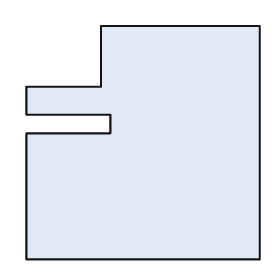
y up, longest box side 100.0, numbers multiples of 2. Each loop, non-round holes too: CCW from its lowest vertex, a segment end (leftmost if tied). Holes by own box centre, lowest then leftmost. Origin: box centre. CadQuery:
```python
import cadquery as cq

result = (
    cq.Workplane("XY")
    .moveTo(-50.0, -50.0)
    .lineTo(50.0, -50.0)
    .lineTo(50.0, 50.0)
    .lineTo(-18.0, 50.0)
    .lineTo(-18.0, 24.0)
    .lineTo(-50.0, 24.0)
    .lineTo(-50.0, 12.0)
    .lineTo(-14.0, 12.0)
    .lineTo(-14.0, 4.0)
    .lineTo(-50.0, 4.0)
    .close()
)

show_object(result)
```